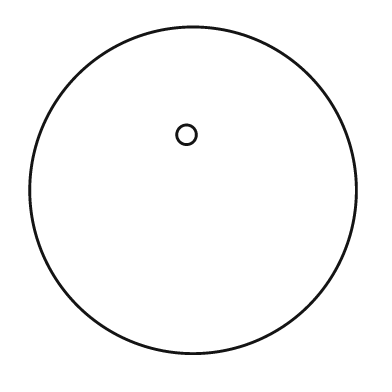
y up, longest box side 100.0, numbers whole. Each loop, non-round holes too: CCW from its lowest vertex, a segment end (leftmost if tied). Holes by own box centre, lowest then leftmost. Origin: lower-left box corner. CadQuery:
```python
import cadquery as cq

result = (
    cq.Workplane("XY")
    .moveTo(50.0, 50.0)
    .circle(50.0)
    .moveTo(48.0, 67.0)
    .circle(3.0)
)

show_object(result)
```